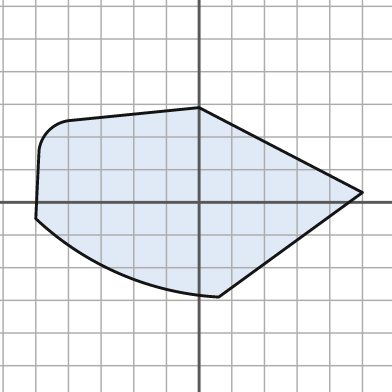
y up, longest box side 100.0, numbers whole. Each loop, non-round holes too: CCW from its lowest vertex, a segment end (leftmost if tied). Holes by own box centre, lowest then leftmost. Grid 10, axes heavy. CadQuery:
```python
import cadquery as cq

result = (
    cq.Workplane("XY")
    .moveTo(6.0, -29.0)
    .lineTo(50.0, 3.0)
    .lineTo(0.0, 29.0)
    .lineTo(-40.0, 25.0)
    .threePointArc((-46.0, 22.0), (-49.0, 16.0))
    .lineTo(-50.0, -5.0)
    .threePointArc((-24.0, -22.0), (6.0, -29.0))
    .close()
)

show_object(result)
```